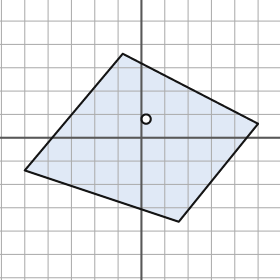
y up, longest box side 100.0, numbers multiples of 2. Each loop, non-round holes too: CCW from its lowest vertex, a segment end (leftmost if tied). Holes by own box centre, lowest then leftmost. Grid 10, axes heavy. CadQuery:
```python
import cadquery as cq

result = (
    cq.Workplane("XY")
    .moveTo(16.0, -36.0)
    .lineTo(50.0, 6.0)
    .lineTo(-8.0, 36.0)
    .lineTo(-50.0, -14.0)
    .close()
    .moveTo(2.0, 8.0)
    .circle(2.0)
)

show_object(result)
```